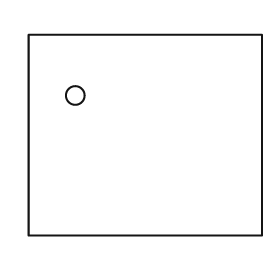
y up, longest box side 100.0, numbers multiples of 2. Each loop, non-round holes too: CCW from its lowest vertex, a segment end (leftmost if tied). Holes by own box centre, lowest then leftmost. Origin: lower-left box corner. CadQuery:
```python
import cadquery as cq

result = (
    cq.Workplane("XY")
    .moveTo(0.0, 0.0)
    .lineTo(100.0, 0.0)
    .lineTo(100.0, 86.0)
    .lineTo(0.0, 86.0)
    .close()
    .moveTo(20.0, 60.0)
    .circle(4.0)
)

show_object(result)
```